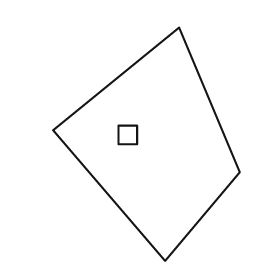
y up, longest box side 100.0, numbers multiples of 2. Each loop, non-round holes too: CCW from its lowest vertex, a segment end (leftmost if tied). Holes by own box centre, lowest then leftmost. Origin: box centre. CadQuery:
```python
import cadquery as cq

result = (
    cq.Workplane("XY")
    .moveTo(8.0, -50.0)
    .lineTo(40.0, -12.0)
    .lineTo(14.0, 50.0)
    .lineTo(-40.0, 6.0)
    .close()
    .moveTo(-12.0, 0.0)
    .lineTo(-4.0, 0.0)
    .lineTo(-4.0, 8.0)
    .lineTo(-12.0, 8.0)
    .close()
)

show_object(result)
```